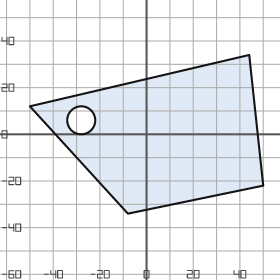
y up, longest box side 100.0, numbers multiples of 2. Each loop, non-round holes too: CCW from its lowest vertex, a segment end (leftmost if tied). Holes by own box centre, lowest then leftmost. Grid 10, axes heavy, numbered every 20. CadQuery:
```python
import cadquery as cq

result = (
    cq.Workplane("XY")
    .moveTo(-8.0, -34.0)
    .lineTo(50.0, -22.0)
    .lineTo(44.0, 34.0)
    .lineTo(-50.0, 12.0)
    .close()
    .moveTo(-28.0, 6.0)
    .circle(6.0)
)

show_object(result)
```